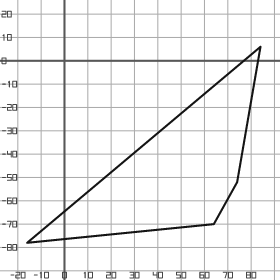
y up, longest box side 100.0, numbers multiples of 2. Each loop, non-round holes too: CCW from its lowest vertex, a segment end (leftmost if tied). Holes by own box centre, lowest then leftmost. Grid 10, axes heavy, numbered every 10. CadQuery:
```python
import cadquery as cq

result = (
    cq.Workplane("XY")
    .moveTo(-16.0, -78.0)
    .lineTo(64.0, -70.0)
    .lineTo(74.0, -52.0)
    .lineTo(84.0, 6.0)
    .close()
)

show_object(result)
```